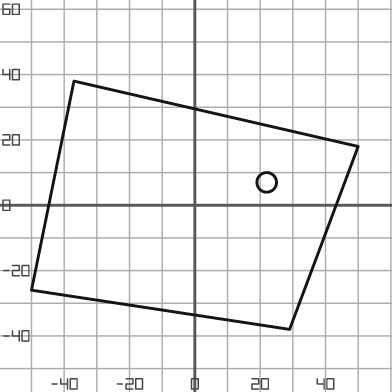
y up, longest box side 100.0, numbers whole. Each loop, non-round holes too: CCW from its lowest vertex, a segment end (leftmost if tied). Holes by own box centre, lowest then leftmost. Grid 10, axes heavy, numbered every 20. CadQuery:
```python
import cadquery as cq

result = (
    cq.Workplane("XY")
    .moveTo(29.0, -38.0)
    .lineTo(50.0, 18.0)
    .lineTo(-37.0, 38.0)
    .lineTo(-50.0, -26.0)
    .close()
    .moveTo(22.0, 7.0)
    .circle(3.0)
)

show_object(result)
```